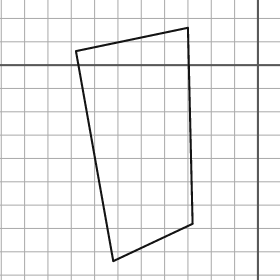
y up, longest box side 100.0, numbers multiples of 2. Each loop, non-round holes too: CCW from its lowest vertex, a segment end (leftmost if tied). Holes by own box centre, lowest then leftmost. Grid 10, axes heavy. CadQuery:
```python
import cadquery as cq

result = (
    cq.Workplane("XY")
    .moveTo(-62.0, -84.0)
    .lineTo(-28.0, -68.0)
    .lineTo(-30.0, 16.0)
    .lineTo(-78.0, 6.0)
    .close()
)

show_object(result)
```